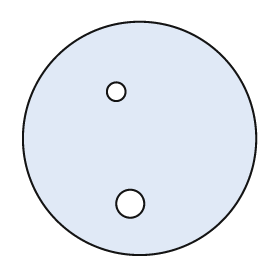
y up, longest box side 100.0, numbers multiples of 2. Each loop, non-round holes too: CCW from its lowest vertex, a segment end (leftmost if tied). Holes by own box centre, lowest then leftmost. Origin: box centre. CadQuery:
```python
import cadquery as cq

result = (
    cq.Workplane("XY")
    .moveTo(0.0, 0.0)
    .circle(50.0)
    .moveTo(-4.0, -28.0)
    .circle(6.0)
    .moveTo(-10.0, 20.0)
    .circle(4.0)
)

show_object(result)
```